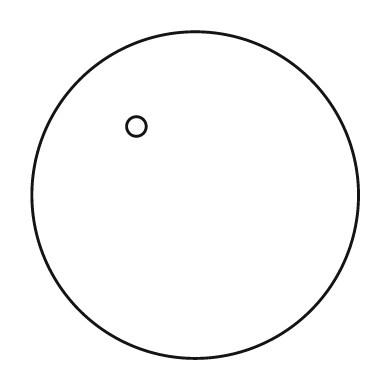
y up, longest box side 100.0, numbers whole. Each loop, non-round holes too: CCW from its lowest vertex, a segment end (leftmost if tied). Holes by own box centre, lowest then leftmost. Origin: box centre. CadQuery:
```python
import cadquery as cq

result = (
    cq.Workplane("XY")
    .moveTo(0.0, 0.0)
    .circle(50.0)
    .moveTo(-18.0, 21.0)
    .circle(3.0)
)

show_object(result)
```